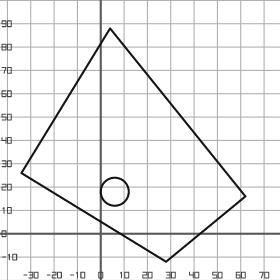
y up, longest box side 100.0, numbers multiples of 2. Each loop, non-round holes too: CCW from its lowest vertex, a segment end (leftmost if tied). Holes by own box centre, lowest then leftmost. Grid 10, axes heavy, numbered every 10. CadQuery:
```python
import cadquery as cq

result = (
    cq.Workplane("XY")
    .moveTo(28.0, -12.0)
    .lineTo(62.0, 16.0)
    .lineTo(4.0, 88.0)
    .lineTo(-34.0, 26.0)
    .close()
    .moveTo(6.0, 18.0)
    .circle(6.0)
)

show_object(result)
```